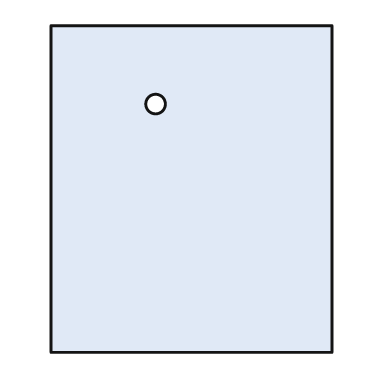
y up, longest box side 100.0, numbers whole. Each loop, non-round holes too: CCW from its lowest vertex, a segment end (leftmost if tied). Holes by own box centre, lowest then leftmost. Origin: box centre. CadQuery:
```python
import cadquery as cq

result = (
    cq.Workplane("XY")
    .moveTo(-43.0, -50.0)
    .lineTo(43.0, -50.0)
    .lineTo(43.0, 50.0)
    .lineTo(-43.0, 50.0)
    .close()
    .moveTo(-11.0, 26.0)
    .circle(3.0)
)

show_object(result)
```